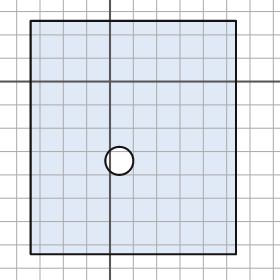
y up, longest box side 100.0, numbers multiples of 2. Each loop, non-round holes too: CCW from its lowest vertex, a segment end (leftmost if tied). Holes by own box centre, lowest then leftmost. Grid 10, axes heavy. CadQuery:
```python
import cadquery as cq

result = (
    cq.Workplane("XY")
    .moveTo(-34.0, -74.0)
    .lineTo(54.0, -74.0)
    .lineTo(54.0, 26.0)
    .lineTo(-34.0, 26.0)
    .close()
    .moveTo(4.0, -34.0)
    .circle(6.0)
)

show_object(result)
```